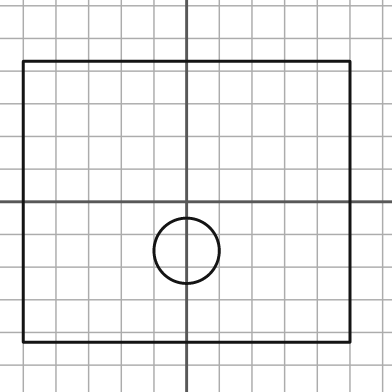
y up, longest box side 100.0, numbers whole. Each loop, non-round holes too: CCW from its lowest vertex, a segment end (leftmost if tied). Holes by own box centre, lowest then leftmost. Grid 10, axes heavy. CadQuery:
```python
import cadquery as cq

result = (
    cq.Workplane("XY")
    .moveTo(-50.0, -43.0)
    .lineTo(50.0, -43.0)
    .lineTo(50.0, 43.0)
    .lineTo(-50.0, 43.0)
    .close()
    .moveTo(0.0, -15.0)
    .circle(10.0)
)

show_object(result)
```